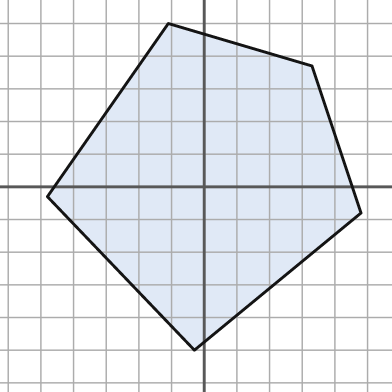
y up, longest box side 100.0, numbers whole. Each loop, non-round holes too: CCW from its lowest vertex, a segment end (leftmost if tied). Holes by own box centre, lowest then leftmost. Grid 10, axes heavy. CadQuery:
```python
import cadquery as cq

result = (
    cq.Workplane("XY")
    .moveTo(-3.0, -50.0)
    .lineTo(48.0, -8.0)
    .lineTo(33.0, 37.0)
    .lineTo(-11.0, 50.0)
    .lineTo(-48.0, -3.0)
    .close()
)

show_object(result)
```